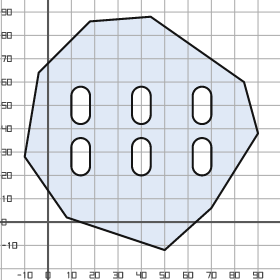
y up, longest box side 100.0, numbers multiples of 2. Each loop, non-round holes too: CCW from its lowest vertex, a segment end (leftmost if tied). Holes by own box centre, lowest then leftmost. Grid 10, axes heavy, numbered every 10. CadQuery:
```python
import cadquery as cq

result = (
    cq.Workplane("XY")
    .moveTo(50.0, -12.0)
    .lineTo(70.0, 6.0)
    .lineTo(90.0, 38.0)
    .lineTo(84.0, 60.0)
    .lineTo(44.0, 88.0)
    .lineTo(18.0, 86.0)
    .lineTo(-4.0, 64.0)
    .lineTo(-10.0, 28.0)
    .lineTo(8.0, 2.0)
    .close()
    .moveTo(10.0, 24.0)
    .threePointArc((14.0, 20.0), (18.0, 24.0))
    .lineTo(18.0, 32.0)
    .threePointArc((14.0, 36.0), (10.0, 32.0))
    .close()
    .moveTo(36.0, 24.0)
    .threePointArc((40.0, 20.0), (44.0, 24.0))
    .lineTo(44.0, 32.0)
    .threePointArc((40.0, 36.0), (36.0, 32.0))
    .close()
    .moveTo(62.0, 24.0)
    .threePointArc((66.0, 20.0), (70.0, 24.0))
    .lineTo(70.0, 32.0)
    .threePointArc((66.0, 36.0), (62.0, 32.0))
    .close()
    .moveTo(10.0, 46.0)
    .threePointArc((14.0, 42.0), (18.0, 46.0))
    .lineTo(18.0, 54.0)
    .threePointArc((14.0, 58.0), (10.0, 54.0))
    .close()
    .moveTo(36.0, 46.0)
    .threePointArc((40.0, 42.0), (44.0, 46.0))
    .lineTo(44.0, 54.0)
    .threePointArc((40.0, 58.0), (36.0, 54.0))
    .close()
    .moveTo(62.0, 46.0)
    .threePointArc((66.0, 42.0), (70.0, 46.0))
    .lineTo(70.0, 54.0)
    .threePointArc((66.0, 58.0), (62.0, 54.0))
    .close()
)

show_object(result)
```